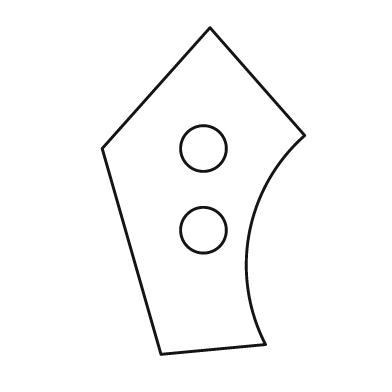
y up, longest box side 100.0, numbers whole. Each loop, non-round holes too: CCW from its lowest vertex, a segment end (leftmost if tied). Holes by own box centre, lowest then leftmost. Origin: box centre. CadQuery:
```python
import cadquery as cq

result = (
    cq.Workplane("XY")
    .moveTo(-13.0, -50.0)
    .lineTo(19.0, -47.0)
    .threePointArc((14.0, -13.0), (31.0, 17.0))
    .lineTo(2.0, 50.0)
    .lineTo(-31.0, 13.0)
    .close()
    .moveTo(0.0, -12.0)
    .circle(7.0)
    .moveTo(0.0, 13.0)
    .circle(7.0)
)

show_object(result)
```